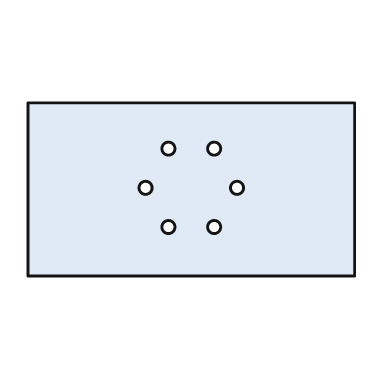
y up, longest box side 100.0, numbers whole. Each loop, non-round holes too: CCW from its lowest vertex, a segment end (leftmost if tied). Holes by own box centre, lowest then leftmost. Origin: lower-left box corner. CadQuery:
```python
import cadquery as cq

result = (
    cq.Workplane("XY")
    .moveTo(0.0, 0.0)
    .lineTo(100.0, 0.0)
    .lineTo(100.0, 53.0)
    .lineTo(0.0, 53.0)
    .close()
    .moveTo(43.0, 15.0)
    .circle(2.0)
    .moveTo(57.0, 15.0)
    .circle(2.0)
    .moveTo(36.0, 27.0)
    .circle(2.0)
    .moveTo(64.0, 27.0)
    .circle(2.0)
    .moveTo(43.0, 39.0)
    .circle(2.0)
    .moveTo(57.0, 39.0)
    .circle(2.0)
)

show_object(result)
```